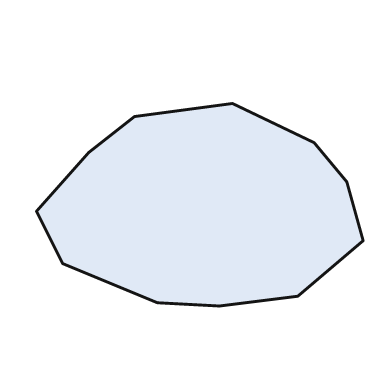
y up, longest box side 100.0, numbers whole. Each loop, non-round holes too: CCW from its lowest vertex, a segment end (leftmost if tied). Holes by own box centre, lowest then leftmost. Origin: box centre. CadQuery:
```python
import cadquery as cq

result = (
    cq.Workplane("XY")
    .moveTo(6.0, -31.0)
    .lineTo(30.0, -28.0)
    .lineTo(50.0, -11.0)
    .lineTo(45.0, 7.0)
    .lineTo(35.0, 19.0)
    .lineTo(10.0, 31.0)
    .lineTo(-20.0, 27.0)
    .lineTo(-34.0, 16.0)
    .lineTo(-50.0, -2.0)
    .lineTo(-42.0, -18.0)
    .lineTo(-13.0, -30.0)
    .close()
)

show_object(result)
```